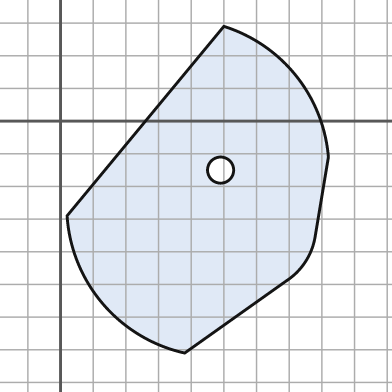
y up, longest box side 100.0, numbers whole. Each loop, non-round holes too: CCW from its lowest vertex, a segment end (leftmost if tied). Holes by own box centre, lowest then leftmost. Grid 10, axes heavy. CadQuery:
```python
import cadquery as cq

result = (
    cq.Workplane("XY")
    .moveTo(38.0, -71.0)
    .lineTo(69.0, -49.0)
    .threePointArc((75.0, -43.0), (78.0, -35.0))
    .lineTo(82.0, -11.0)
    .threePointArc((72.0, 14.0), (50.0, 29.0))
    .lineTo(2.0, -29.0)
    .threePointArc((13.0, -56.0), (38.0, -71.0))
    .close()
    .moveTo(49.0, -15.0)
    .circle(4.0)
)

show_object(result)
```